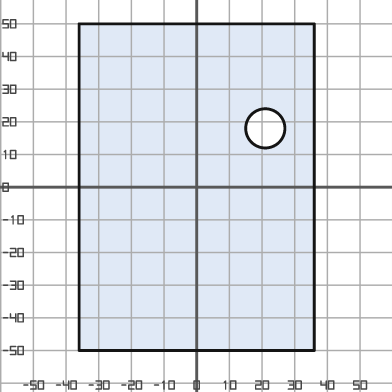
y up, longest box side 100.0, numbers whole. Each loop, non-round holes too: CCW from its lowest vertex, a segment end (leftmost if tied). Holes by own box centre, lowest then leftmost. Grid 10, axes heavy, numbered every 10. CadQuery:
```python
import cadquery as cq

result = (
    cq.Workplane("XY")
    .moveTo(-36.0, -50.0)
    .lineTo(36.0, -50.0)
    .lineTo(36.0, 50.0)
    .lineTo(-36.0, 50.0)
    .close()
    .moveTo(21.0, 18.0)
    .circle(6.0)
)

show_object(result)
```